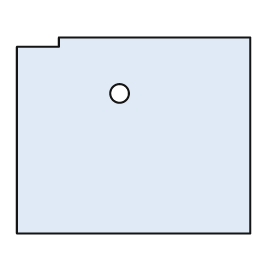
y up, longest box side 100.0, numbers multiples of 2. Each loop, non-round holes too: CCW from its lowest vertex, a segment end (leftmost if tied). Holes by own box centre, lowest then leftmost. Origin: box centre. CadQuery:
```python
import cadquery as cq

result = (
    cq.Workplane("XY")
    .moveTo(-50.0, -42.0)
    .lineTo(50.0, -42.0)
    .lineTo(50.0, 42.0)
    .lineTo(-32.0, 42.0)
    .lineTo(-32.0, 38.0)
    .lineTo(-50.0, 38.0)
    .close()
    .moveTo(-6.0, 18.0)
    .circle(4.0)
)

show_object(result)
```